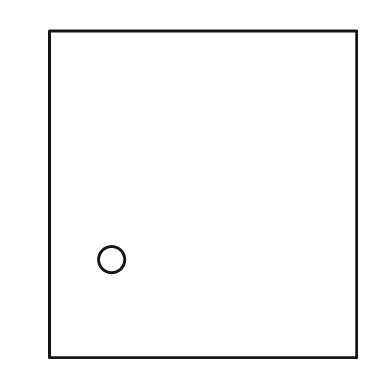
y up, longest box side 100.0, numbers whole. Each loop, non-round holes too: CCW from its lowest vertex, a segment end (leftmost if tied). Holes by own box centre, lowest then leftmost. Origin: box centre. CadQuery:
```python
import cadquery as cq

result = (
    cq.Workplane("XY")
    .moveTo(-47.0, -50.0)
    .lineTo(47.0, -50.0)
    .lineTo(47.0, 50.0)
    .lineTo(-47.0, 50.0)
    .close()
    .moveTo(-28.0, -20.0)
    .circle(4.0)
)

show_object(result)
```